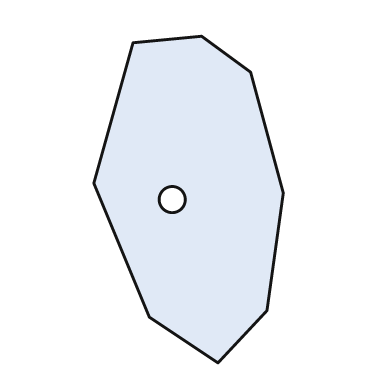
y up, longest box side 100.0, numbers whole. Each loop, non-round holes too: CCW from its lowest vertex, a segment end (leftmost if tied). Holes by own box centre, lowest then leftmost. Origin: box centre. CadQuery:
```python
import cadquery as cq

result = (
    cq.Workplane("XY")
    .moveTo(9.0, -50.0)
    .lineTo(24.0, -34.0)
    .lineTo(29.0, 2.0)
    .lineTo(19.0, 39.0)
    .lineTo(4.0, 50.0)
    .lineTo(-17.0, 48.0)
    .lineTo(-29.0, 5.0)
    .lineTo(-12.0, -36.0)
    .close()
    .moveTo(-5.0, 0.0)
    .circle(4.0)
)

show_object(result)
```